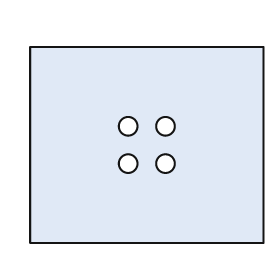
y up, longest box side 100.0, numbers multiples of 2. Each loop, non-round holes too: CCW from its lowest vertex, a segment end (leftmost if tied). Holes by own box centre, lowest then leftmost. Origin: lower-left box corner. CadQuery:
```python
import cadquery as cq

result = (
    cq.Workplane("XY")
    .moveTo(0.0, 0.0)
    .lineTo(100.0, 0.0)
    .lineTo(100.0, 84.0)
    .lineTo(0.0, 84.0)
    .close()
    .moveTo(42.0, 34.0)
    .circle(4.0)
    .moveTo(58.0, 34.0)
    .circle(4.0)
    .moveTo(42.0, 50.0)
    .circle(4.0)
    .moveTo(58.0, 50.0)
    .circle(4.0)
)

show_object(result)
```